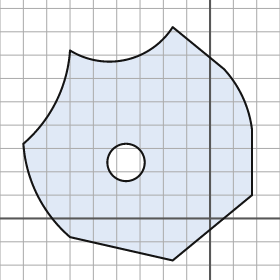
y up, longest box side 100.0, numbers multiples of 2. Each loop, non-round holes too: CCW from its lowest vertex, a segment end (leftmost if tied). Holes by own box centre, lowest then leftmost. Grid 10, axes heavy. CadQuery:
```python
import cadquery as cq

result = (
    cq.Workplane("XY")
    .moveTo(-16.0, -18.0)
    .lineTo(18.0, 10.0)
    .lineTo(18.0, 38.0)
    .threePointArc((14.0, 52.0), (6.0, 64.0))
    .lineTo(-16.0, 82.0)
    .threePointArc((-36.0, 68.0), (-60.0, 72.0))
    .threePointArc((-66.0, 50.0), (-80.0, 32.0))
    .threePointArc((-74.0, 10.0), (-60.0, -8.0))
    .close()
    .moveTo(-36.0, 24.0)
    .circle(8.0)
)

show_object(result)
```